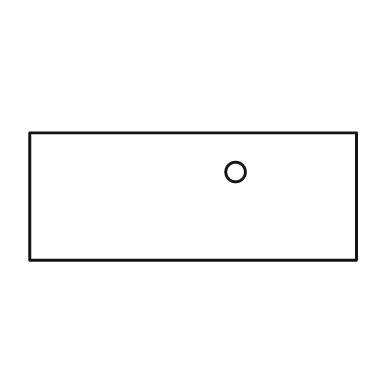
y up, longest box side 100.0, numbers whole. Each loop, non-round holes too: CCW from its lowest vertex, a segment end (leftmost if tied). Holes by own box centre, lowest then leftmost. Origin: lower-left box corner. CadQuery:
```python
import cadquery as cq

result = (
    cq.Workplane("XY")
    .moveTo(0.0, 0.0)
    .lineTo(100.0, 0.0)
    .lineTo(100.0, 39.0)
    .lineTo(0.0, 39.0)
    .close()
    .moveTo(63.0, 27.0)
    .circle(3.0)
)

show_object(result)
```